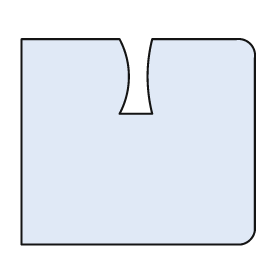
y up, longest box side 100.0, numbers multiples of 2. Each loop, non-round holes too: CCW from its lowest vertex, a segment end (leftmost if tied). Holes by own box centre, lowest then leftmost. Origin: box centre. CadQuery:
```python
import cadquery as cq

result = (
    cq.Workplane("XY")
    .moveTo(-50.0, -44.0)
    .lineTo(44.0, -44.0)
    .threePointArc((48.0, -42.0), (50.0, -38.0))
    .lineTo(50.0, 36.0)
    .threePointArc((48.0, 42.0), (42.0, 44.0))
    .lineTo(6.0, 44.0)
    .threePointArc((4.0, 28.0), (6.0, 12.0))
    .lineTo(-8.0, 12.0)
    .threePointArc((-4.0, 28.0), (-8.0, 44.0))
    .lineTo(-50.0, 44.0)
    .close()
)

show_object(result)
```